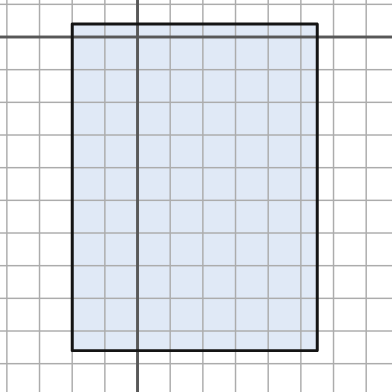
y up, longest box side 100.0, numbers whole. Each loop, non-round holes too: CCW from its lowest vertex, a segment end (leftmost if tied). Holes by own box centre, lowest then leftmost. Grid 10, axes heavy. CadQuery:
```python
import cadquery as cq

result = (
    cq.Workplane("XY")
    .moveTo(-20.0, -96.0)
    .lineTo(55.0, -96.0)
    .lineTo(55.0, 4.0)
    .lineTo(-20.0, 4.0)
    .close()
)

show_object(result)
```